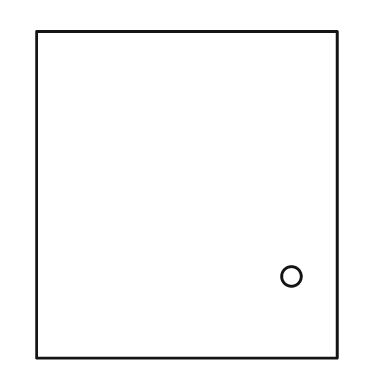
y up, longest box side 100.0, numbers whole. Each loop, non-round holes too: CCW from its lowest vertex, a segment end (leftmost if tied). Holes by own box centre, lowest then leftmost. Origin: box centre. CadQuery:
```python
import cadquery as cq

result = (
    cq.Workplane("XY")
    .moveTo(-46.0, -50.0)
    .lineTo(46.0, -50.0)
    .lineTo(46.0, 50.0)
    .lineTo(-46.0, 50.0)
    .close()
    .moveTo(32.0, -25.0)
    .circle(3.0)
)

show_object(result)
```